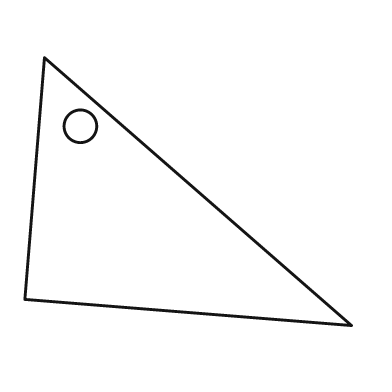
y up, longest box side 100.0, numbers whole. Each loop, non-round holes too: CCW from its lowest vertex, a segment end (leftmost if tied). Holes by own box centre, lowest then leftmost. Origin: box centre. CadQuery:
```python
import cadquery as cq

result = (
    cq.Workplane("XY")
    .moveTo(50.0, -41.0)
    .lineTo(-44.0, 41.0)
    .lineTo(-50.0, -33.0)
    .close()
    .moveTo(-33.0, 20.0)
    .circle(5.0)
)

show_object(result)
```